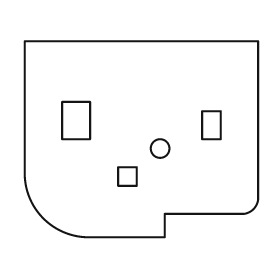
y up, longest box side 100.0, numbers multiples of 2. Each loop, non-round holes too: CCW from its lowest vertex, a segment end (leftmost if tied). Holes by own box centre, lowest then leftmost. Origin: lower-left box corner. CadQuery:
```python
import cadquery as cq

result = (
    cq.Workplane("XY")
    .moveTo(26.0, 0.0)
    .lineTo(60.0, 0.0)
    .lineTo(60.0, 10.0)
    .lineTo(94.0, 10.0)
    .threePointArc((98.0, 12.0), (100.0, 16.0))
    .lineTo(100.0, 84.0)
    .lineTo(0.0, 84.0)
    .lineTo(0.0, 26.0)
    .threePointArc((8.0, 8.0), (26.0, 0.0))
    .close()
    .moveTo(40.0, 22.0)
    .lineTo(48.0, 22.0)
    .lineTo(48.0, 30.0)
    .lineTo(40.0, 30.0)
    .close()
    .moveTo(58.0, 38.0)
    .circle(4.0)
    .moveTo(76.0, 42.0)
    .lineTo(84.0, 42.0)
    .lineTo(84.0, 54.0)
    .lineTo(76.0, 54.0)
    .close()
    .moveTo(16.0, 42.0)
    .lineTo(28.0, 42.0)
    .lineTo(28.0, 58.0)
    .lineTo(16.0, 58.0)
    .close()
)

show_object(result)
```